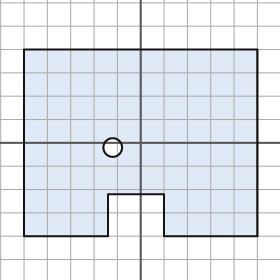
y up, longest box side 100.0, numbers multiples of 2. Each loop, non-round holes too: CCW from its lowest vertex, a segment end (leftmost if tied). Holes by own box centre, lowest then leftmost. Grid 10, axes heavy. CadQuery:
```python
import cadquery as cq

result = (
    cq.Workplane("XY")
    .moveTo(-50.0, -40.0)
    .lineTo(-14.0, -40.0)
    .lineTo(-14.0, -22.0)
    .lineTo(10.0, -22.0)
    .lineTo(10.0, -40.0)
    .lineTo(50.0, -40.0)
    .lineTo(50.0, 40.0)
    .lineTo(-50.0, 40.0)
    .close()
    .moveTo(-12.0, -2.0)
    .circle(4.0)
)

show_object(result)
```